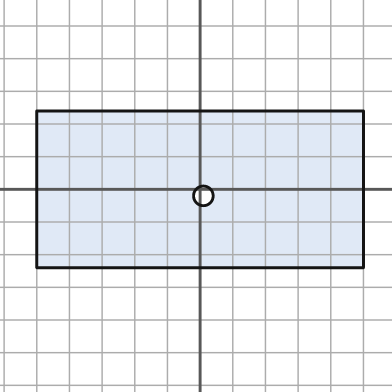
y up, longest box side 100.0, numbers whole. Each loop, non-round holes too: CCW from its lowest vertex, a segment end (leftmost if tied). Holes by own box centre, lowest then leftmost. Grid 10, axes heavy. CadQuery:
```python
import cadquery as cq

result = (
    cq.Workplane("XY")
    .moveTo(-50.0, -24.0)
    .lineTo(50.0, -24.0)
    .lineTo(50.0, 24.0)
    .lineTo(-50.0, 24.0)
    .close()
    .moveTo(1.0, -2.0)
    .circle(3.0)
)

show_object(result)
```